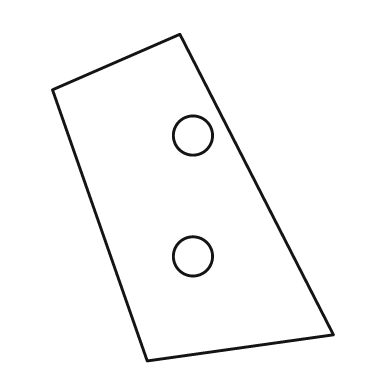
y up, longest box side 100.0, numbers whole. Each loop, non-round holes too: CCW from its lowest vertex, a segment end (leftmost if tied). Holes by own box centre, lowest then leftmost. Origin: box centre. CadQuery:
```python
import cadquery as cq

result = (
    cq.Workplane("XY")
    .moveTo(-14.0, -50.0)
    .lineTo(43.0, -42.0)
    .lineTo(-4.0, 50.0)
    .lineTo(-43.0, 33.0)
    .close()
    .moveTo(0.0, -18.0)
    .circle(6.0)
    .moveTo(0.0, 19.0)
    .circle(6.0)
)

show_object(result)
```